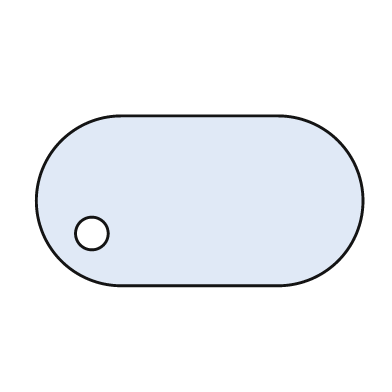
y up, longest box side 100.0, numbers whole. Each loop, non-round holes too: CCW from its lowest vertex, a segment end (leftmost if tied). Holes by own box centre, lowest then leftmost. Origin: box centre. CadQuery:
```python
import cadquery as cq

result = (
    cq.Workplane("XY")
    .moveTo(-24.0, -26.0)
    .lineTo(24.0, -26.0)
    .threePointArc((50.0, 0.0), (24.0, 26.0))
    .lineTo(-24.0, 26.0)
    .threePointArc((-50.0, 0.0), (-24.0, -26.0))
    .close()
    .moveTo(-33.0, -10.0)
    .circle(5.0)
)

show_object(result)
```